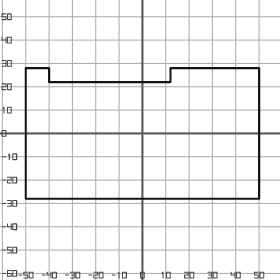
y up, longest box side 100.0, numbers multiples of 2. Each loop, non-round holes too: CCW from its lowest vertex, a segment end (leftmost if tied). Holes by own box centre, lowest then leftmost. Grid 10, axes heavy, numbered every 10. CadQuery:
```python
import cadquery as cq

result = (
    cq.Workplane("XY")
    .moveTo(-50.0, -28.0)
    .lineTo(50.0, -28.0)
    .lineTo(50.0, 28.0)
    .lineTo(12.0, 28.0)
    .lineTo(12.0, 22.0)
    .lineTo(-40.0, 22.0)
    .lineTo(-40.0, 28.0)
    .lineTo(-50.0, 28.0)
    .close()
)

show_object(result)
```